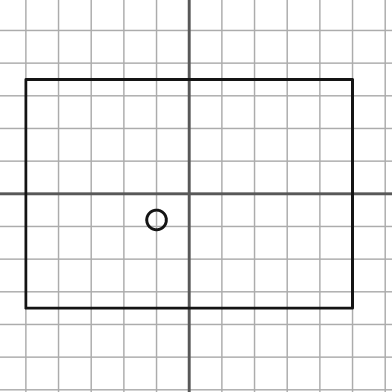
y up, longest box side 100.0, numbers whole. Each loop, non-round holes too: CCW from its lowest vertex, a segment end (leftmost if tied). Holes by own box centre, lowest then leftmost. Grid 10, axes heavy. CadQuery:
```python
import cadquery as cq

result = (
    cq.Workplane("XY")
    .moveTo(-50.0, -35.0)
    .lineTo(50.0, -35.0)
    .lineTo(50.0, 35.0)
    .lineTo(-50.0, 35.0)
    .close()
    .moveTo(-10.0, -8.0)
    .circle(3.0)
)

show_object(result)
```